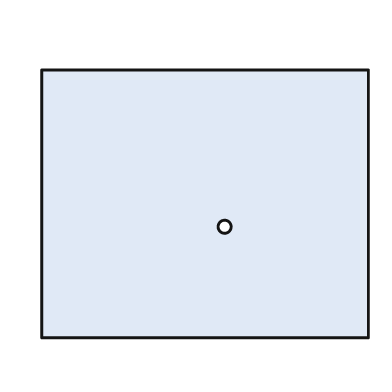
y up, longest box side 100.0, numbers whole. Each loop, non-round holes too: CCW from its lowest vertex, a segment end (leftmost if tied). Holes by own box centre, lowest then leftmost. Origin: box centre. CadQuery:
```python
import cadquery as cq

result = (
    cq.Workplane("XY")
    .moveTo(-50.0, -41.0)
    .lineTo(50.0, -41.0)
    .lineTo(50.0, 41.0)
    .lineTo(-50.0, 41.0)
    .close()
    .moveTo(6.0, -7.0)
    .circle(2.0)
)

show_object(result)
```